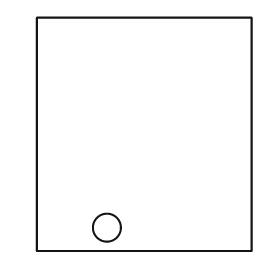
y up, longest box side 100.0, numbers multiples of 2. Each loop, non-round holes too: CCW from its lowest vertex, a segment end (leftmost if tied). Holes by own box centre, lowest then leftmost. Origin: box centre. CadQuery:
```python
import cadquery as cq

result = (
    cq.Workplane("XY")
    .moveTo(-46.0, -50.0)
    .lineTo(46.0, -50.0)
    .lineTo(46.0, 50.0)
    .lineTo(-46.0, 50.0)
    .close()
    .moveTo(-16.0, -40.0)
    .circle(6.0)
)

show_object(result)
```